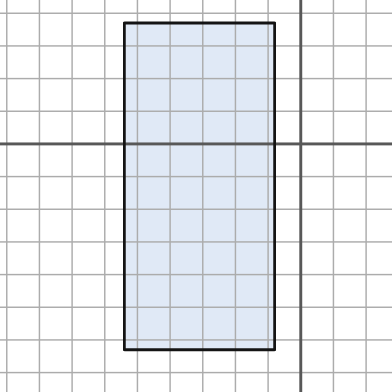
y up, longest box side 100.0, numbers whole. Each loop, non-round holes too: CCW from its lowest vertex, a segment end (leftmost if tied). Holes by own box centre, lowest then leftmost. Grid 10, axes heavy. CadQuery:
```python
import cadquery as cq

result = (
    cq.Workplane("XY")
    .moveTo(-54.0, -63.0)
    .lineTo(-8.0, -63.0)
    .lineTo(-8.0, 37.0)
    .lineTo(-54.0, 37.0)
    .close()
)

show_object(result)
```